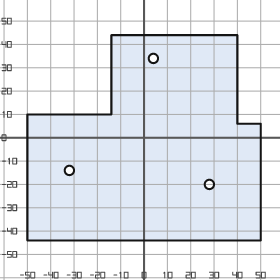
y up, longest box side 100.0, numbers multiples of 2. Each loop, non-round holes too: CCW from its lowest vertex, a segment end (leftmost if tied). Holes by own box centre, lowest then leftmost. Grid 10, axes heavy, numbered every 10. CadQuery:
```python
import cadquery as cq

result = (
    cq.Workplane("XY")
    .moveTo(-50.0, -44.0)
    .lineTo(50.0, -44.0)
    .lineTo(50.0, 6.0)
    .lineTo(40.0, 6.0)
    .lineTo(40.0, 44.0)
    .lineTo(-14.0, 44.0)
    .lineTo(-14.0, 10.0)
    .lineTo(-50.0, 10.0)
    .close()
    .moveTo(28.0, -20.0)
    .circle(2.0)
    .moveTo(-32.0, -14.0)
    .circle(2.0)
    .moveTo(4.0, 34.0)
    .circle(2.0)
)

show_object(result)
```